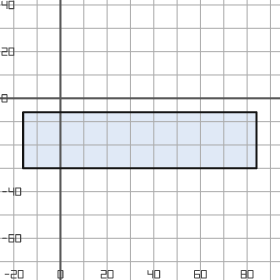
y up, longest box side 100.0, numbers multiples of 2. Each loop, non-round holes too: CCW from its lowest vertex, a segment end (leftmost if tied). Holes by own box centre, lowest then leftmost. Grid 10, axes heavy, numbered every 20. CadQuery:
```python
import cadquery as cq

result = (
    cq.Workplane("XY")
    .moveTo(-16.0, -30.0)
    .lineTo(84.0, -30.0)
    .lineTo(84.0, -6.0)
    .lineTo(-16.0, -6.0)
    .close()
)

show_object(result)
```